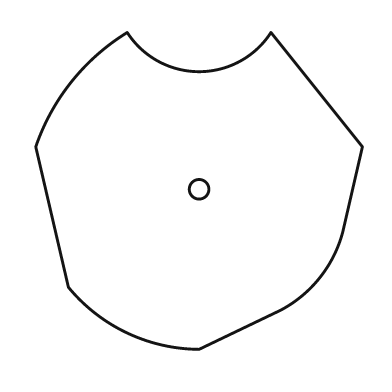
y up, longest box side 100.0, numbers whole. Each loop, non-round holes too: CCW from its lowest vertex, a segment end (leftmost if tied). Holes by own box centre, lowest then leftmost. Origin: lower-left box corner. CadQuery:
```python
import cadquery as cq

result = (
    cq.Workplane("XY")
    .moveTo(50.0, 0.0)
    .lineTo(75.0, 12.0)
    .threePointArc((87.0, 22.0), (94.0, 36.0))
    .lineTo(100.0, 62.0)
    .lineTo(72.0, 97.0)
    .threePointArc((50.0, 85.0), (28.0, 97.0))
    .threePointArc((11.0, 82.0), (0.0, 62.0))
    .lineTo(10.0, 19.0)
    .threePointArc((28.0, 5.0), (50.0, 0.0))
    .close()
    .moveTo(50.0, 49.0)
    .circle(3.0)
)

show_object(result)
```